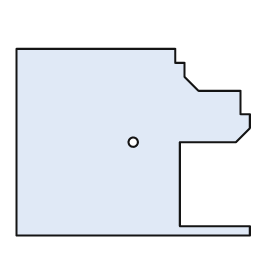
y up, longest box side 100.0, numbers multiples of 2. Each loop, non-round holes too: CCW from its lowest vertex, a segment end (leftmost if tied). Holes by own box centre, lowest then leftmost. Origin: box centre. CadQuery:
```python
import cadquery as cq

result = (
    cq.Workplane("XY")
    .moveTo(-50.0, -40.0)
    .lineTo(50.0, -40.0)
    .lineTo(50.0, -36.0)
    .lineTo(20.0, -36.0)
    .lineTo(20.0, 0.0)
    .lineTo(44.0, 0.0)
    .lineTo(50.0, 6.0)
    .lineTo(50.0, 12.0)
    .lineTo(46.0, 12.0)
    .lineTo(46.0, 22.0)
    .lineTo(28.0, 22.0)
    .lineTo(22.0, 28.0)
    .lineTo(22.0, 34.0)
    .lineTo(18.0, 34.0)
    .lineTo(18.0, 40.0)
    .lineTo(-50.0, 40.0)
    .close()
    .moveTo(0.0, 0.0)
    .circle(2.0)
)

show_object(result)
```